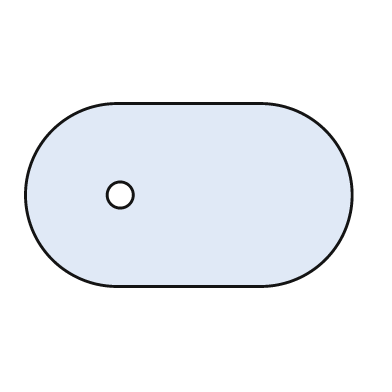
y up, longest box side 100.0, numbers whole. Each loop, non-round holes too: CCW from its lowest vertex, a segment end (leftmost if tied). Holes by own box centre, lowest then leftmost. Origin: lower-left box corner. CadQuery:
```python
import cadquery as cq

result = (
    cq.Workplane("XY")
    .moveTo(28.0, 0.0)
    .lineTo(72.0, 0.0)
    .threePointArc((100.0, 28.0), (72.0, 56.0))
    .lineTo(28.0, 56.0)
    .threePointArc((0.0, 28.0), (28.0, 0.0))
    .close()
    .moveTo(29.0, 28.0)
    .circle(4.0)
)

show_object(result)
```